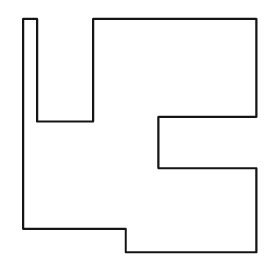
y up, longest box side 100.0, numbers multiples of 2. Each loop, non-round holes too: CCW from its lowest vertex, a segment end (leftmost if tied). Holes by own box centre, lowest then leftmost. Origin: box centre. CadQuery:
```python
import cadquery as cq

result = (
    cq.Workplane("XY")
    .moveTo(-6.0, -50.0)
    .lineTo(50.0, -50.0)
    .lineTo(50.0, -14.0)
    .lineTo(8.0, -14.0)
    .lineTo(8.0, 8.0)
    .lineTo(50.0, 8.0)
    .lineTo(50.0, 50.0)
    .lineTo(-20.0, 50.0)
    .lineTo(-20.0, 6.0)
    .lineTo(-44.0, 6.0)
    .lineTo(-44.0, 50.0)
    .lineTo(-50.0, 50.0)
    .lineTo(-50.0, -40.0)
    .lineTo(-6.0, -40.0)
    .close()
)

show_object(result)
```